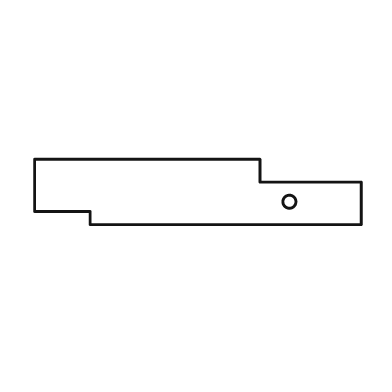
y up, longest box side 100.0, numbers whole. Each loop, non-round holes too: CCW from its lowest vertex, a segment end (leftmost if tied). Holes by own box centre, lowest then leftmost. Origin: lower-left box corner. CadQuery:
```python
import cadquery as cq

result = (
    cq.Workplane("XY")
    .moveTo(17.0, 0.0)
    .lineTo(100.0, 0.0)
    .lineTo(100.0, 13.0)
    .lineTo(69.0, 13.0)
    .lineTo(69.0, 20.0)
    .lineTo(0.0, 20.0)
    .lineTo(0.0, 4.0)
    .lineTo(17.0, 4.0)
    .close()
    .moveTo(78.0, 7.0)
    .circle(2.0)
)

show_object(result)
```